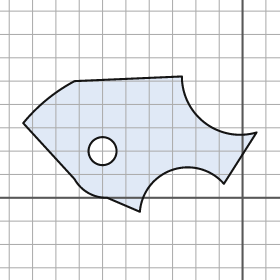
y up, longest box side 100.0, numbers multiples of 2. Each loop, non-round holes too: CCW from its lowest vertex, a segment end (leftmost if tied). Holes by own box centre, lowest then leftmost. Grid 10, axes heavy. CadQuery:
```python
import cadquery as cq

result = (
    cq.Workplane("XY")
    .moveTo(-44.0, -6.0)
    .threePointArc((-30.0, 12.0), (-8.0, 6.0))
    .lineTo(6.0, 28.0)
    .threePointArc((-16.0, 32.0), (-26.0, 52.0))
    .lineTo(-72.0, 50.0)
    .threePointArc((-84.0, 42.0), (-94.0, 32.0))
    .lineTo(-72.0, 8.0)
    .threePointArc((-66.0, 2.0), (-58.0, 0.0))
    .close()
    .moveTo(-60.0, 20.0)
    .circle(6.0)
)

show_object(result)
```